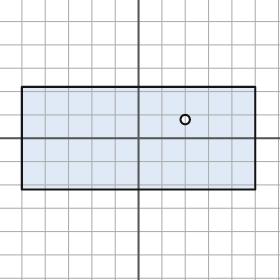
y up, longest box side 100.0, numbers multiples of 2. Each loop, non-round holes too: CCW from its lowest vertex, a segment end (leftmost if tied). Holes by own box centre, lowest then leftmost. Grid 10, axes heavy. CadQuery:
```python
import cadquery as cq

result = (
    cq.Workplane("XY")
    .moveTo(-50.0, -22.0)
    .lineTo(50.0, -22.0)
    .lineTo(50.0, 22.0)
    .lineTo(-50.0, 22.0)
    .close()
    .moveTo(20.0, 8.0)
    .circle(2.0)
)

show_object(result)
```